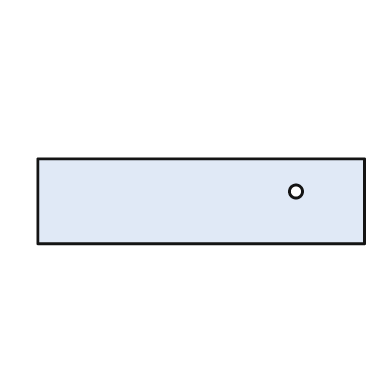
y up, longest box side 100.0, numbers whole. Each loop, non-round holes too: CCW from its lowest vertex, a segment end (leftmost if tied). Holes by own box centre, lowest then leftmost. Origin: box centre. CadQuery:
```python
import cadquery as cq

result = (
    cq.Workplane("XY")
    .moveTo(-50.0, -13.0)
    .lineTo(50.0, -13.0)
    .lineTo(50.0, 13.0)
    .lineTo(-50.0, 13.0)
    .close()
    .moveTo(29.0, 3.0)
    .circle(2.0)
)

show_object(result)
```